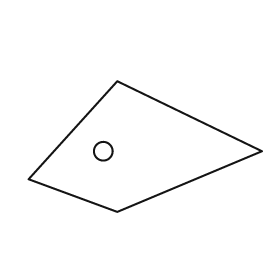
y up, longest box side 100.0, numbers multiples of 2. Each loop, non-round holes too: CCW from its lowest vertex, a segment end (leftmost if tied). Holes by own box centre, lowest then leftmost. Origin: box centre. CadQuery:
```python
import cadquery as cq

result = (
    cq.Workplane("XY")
    .moveTo(-12.0, -28.0)
    .lineTo(50.0, -2.0)
    .lineTo(-12.0, 28.0)
    .lineTo(-50.0, -14.0)
    .close()
    .moveTo(-18.0, -2.0)
    .circle(4.0)
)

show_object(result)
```